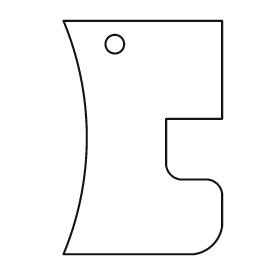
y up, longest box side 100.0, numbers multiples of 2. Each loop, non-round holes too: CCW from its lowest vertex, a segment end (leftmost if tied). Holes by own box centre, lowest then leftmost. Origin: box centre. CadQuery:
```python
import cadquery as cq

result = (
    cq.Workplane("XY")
    .moveTo(-34.0, -50.0)
    .lineTo(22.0, -50.0)
    .threePointArc((30.0, -46.0), (34.0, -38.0))
    .lineTo(34.0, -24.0)
    .threePointArc((32.0, -20.0), (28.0, -18.0))
    .lineTo(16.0, -18.0)
    .threePointArc((12.0, -16.0), (10.0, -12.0))
    .lineTo(10.0, 8.0)
    .lineTo(34.0, 8.0)
    .lineTo(34.0, 50.0)
    .lineTo(-34.0, 50.0)
    .threePointArc((-24.0, 0.0), (-34.0, -50.0))
    .close()
    .moveTo(-12.0, 40.0)
    .circle(4.0)
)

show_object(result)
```